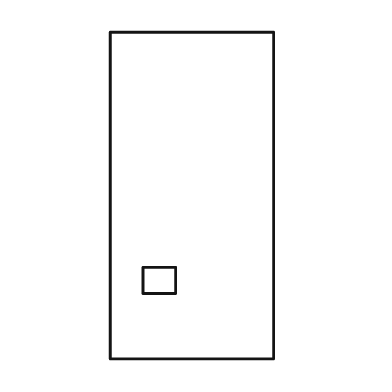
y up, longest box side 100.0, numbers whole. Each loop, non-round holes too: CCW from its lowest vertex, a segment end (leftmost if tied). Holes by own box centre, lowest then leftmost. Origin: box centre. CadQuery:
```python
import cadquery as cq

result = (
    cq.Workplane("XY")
    .moveTo(-25.0, -50.0)
    .lineTo(25.0, -50.0)
    .lineTo(25.0, 50.0)
    .lineTo(-25.0, 50.0)
    .close()
    .moveTo(-15.0, -30.0)
    .lineTo(-5.0, -30.0)
    .lineTo(-5.0, -22.0)
    .lineTo(-15.0, -22.0)
    .close()
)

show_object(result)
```